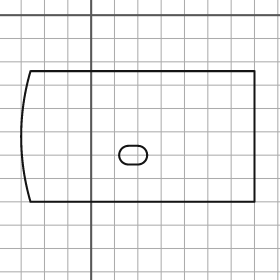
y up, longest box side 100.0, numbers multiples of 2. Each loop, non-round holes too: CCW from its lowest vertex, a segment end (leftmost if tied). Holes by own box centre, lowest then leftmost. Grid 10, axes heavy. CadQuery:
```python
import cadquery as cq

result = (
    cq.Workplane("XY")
    .moveTo(-26.0, -80.0)
    .lineTo(70.0, -80.0)
    .lineTo(70.0, -24.0)
    .lineTo(-26.0, -24.0)
    .threePointArc((-30.0, -52.0), (-26.0, -80.0))
    .close()
    .moveTo(16.0, -64.0)
    .lineTo(20.0, -64.0)
    .threePointArc((24.0, -60.0), (20.0, -56.0))
    .lineTo(16.0, -56.0)
    .threePointArc((12.0, -60.0), (16.0, -64.0))
    .close()
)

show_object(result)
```